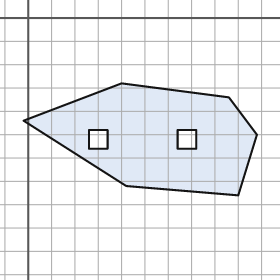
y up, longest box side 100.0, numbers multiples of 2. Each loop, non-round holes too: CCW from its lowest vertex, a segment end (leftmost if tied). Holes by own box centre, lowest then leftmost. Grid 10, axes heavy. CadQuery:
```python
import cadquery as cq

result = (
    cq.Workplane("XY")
    .moveTo(90.0, -76.0)
    .lineTo(98.0, -50.0)
    .lineTo(86.0, -34.0)
    .lineTo(40.0, -28.0)
    .lineTo(-2.0, -44.0)
    .lineTo(42.0, -72.0)
    .close()
    .moveTo(26.0, -56.0)
    .lineTo(34.0, -56.0)
    .lineTo(34.0, -48.0)
    .lineTo(26.0, -48.0)
    .close()
    .moveTo(64.0, -56.0)
    .lineTo(72.0, -56.0)
    .lineTo(72.0, -48.0)
    .lineTo(64.0, -48.0)
    .close()
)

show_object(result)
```